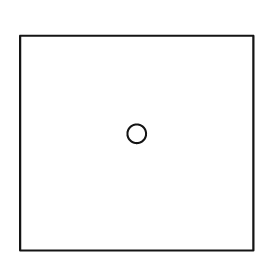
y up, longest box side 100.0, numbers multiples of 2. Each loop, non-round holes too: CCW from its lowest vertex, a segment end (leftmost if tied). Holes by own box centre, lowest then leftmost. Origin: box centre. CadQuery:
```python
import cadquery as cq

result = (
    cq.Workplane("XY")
    .moveTo(-50.0, -46.0)
    .lineTo(50.0, -46.0)
    .lineTo(50.0, 46.0)
    .lineTo(-50.0, 46.0)
    .close()
    .moveTo(0.0, 4.0)
    .circle(4.0)
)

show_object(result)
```